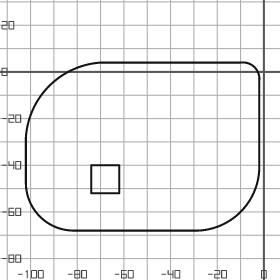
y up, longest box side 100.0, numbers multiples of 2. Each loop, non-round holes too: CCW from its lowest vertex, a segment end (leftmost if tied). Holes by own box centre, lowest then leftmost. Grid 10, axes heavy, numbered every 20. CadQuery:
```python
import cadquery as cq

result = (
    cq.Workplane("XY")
    .moveTo(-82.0, -68.0)
    .lineTo(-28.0, -68.0)
    .threePointArc((-10.0, -60.0), (-2.0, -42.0))
    .lineTo(-2.0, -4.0)
    .threePointArc((-4.0, 2.0), (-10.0, 4.0))
    .lineTo(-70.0, 4.0)
    .threePointArc((-92.0, -6.0), (-102.0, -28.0))
    .lineTo(-102.0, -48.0)
    .threePointArc((-96.0, -62.0), (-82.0, -68.0))
    .close()
    .moveTo(-74.0, -52.0)
    .lineTo(-62.0, -52.0)
    .lineTo(-62.0, -40.0)
    .lineTo(-74.0, -40.0)
    .close()
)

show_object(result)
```